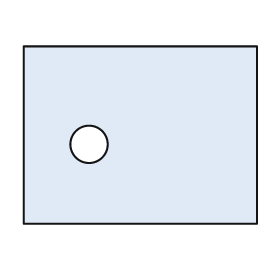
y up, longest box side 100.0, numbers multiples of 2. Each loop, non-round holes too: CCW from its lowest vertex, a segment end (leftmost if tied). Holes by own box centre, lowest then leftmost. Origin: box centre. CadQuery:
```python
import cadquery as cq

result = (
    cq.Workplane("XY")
    .moveTo(-50.0, -38.0)
    .lineTo(50.0, -38.0)
    .lineTo(50.0, 38.0)
    .lineTo(-50.0, 38.0)
    .close()
    .moveTo(-22.0, -4.0)
    .circle(8.0)
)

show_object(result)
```